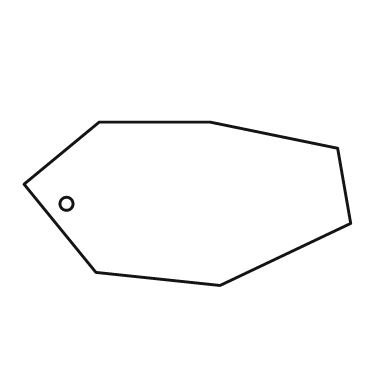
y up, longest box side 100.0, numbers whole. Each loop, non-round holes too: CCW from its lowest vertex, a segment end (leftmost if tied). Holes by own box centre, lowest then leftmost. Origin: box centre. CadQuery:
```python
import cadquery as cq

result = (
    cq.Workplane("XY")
    .moveTo(10.0, -25.0)
    .lineTo(50.0, -6.0)
    .lineTo(46.0, 17.0)
    .lineTo(7.0, 25.0)
    .lineTo(-27.0, 25.0)
    .lineTo(-50.0, 6.0)
    .lineTo(-28.0, -21.0)
    .close()
    .moveTo(-37.0, 0.0)
    .circle(2.0)
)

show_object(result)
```